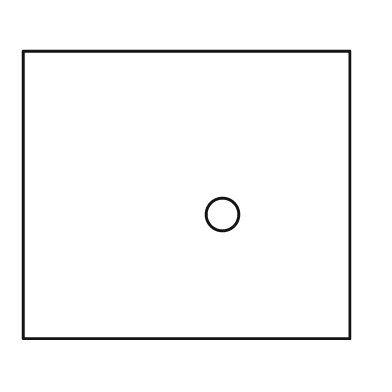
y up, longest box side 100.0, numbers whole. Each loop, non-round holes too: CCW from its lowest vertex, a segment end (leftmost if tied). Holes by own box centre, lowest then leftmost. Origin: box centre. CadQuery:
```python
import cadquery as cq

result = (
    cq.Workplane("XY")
    .moveTo(-50.0, -44.0)
    .lineTo(50.0, -44.0)
    .lineTo(50.0, 44.0)
    .lineTo(-50.0, 44.0)
    .close()
    .moveTo(11.0, -6.0)
    .circle(5.0)
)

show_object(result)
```